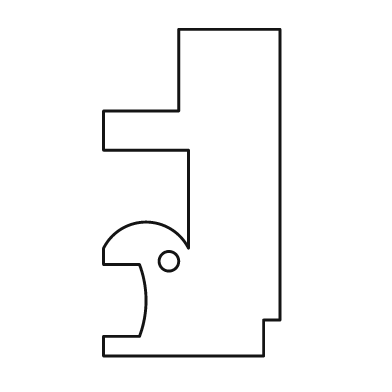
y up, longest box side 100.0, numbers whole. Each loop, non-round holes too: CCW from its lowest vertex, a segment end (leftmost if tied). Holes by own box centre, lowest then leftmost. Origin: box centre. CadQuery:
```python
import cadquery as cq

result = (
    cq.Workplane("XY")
    .moveTo(-27.0, -50.0)
    .lineTo(22.0, -50.0)
    .lineTo(22.0, -39.0)
    .lineTo(27.0, -39.0)
    .lineTo(27.0, 50.0)
    .lineTo(-4.0, 50.0)
    .lineTo(-4.0, 25.0)
    .lineTo(-27.0, 25.0)
    .lineTo(-27.0, 13.0)
    .lineTo(-1.0, 13.0)
    .lineTo(-1.0, -17.0)
    .threePointArc((-14.0, -9.0), (-27.0, -17.0))
    .lineTo(-27.0, -22.0)
    .lineTo(-16.0, -22.0)
    .threePointArc((-14.0, -33.0), (-16.0, -44.0))
    .lineTo(-27.0, -44.0)
    .close()
    .moveTo(-7.0, -21.0)
    .circle(3.0)
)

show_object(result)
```